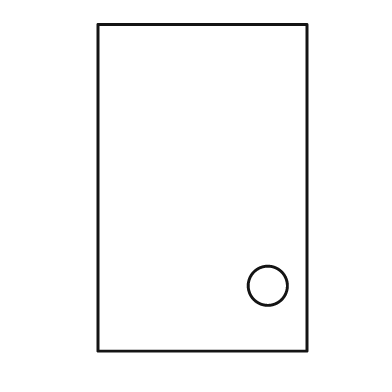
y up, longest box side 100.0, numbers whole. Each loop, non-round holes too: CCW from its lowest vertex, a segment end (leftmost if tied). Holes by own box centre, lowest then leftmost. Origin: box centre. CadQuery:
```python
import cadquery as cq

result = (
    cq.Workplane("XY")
    .moveTo(-32.0, -50.0)
    .lineTo(32.0, -50.0)
    .lineTo(32.0, 50.0)
    .lineTo(-32.0, 50.0)
    .close()
    .moveTo(20.0, -30.0)
    .circle(6.0)
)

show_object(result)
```